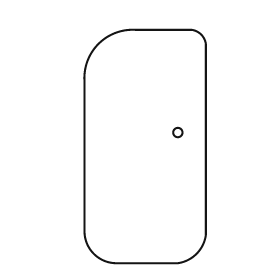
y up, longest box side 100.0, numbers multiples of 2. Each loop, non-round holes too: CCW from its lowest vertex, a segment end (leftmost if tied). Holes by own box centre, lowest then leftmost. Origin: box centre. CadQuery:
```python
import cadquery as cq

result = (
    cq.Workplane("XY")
    .moveTo(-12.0, -50.0)
    .lineTo(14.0, -50.0)
    .threePointArc((22.0, -46.0), (26.0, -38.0))
    .lineTo(26.0, 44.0)
    .threePointArc((24.0, 48.0), (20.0, 50.0))
    .lineTo(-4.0, 50.0)
    .threePointArc((-20.0, 44.0), (-26.0, 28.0))
    .lineTo(-26.0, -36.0)
    .threePointArc((-22.0, -46.0), (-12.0, -50.0))
    .close()
    .moveTo(14.0, 6.0)
    .circle(2.0)
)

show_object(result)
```